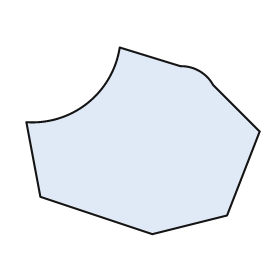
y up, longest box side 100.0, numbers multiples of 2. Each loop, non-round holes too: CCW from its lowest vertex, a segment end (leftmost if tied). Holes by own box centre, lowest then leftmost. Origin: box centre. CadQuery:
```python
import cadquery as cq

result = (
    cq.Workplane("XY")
    .moveTo(4.0, -40.0)
    .lineTo(36.0, -32.0)
    .lineTo(50.0, 4.0)
    .lineTo(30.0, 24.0)
    .threePointArc((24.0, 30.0), (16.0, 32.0))
    .lineTo(-10.0, 40.0)
    .threePointArc((-24.0, 16.0), (-50.0, 8.0))
    .lineTo(-44.0, -24.0)
    .close()
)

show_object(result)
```